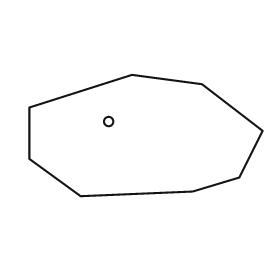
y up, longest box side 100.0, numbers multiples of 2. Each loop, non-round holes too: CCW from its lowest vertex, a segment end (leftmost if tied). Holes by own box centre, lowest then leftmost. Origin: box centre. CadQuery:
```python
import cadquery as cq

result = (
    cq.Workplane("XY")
    .moveTo(-28.0, -26.0)
    .lineTo(20.0, -24.0)
    .lineTo(40.0, -18.0)
    .lineTo(50.0, 2.0)
    .lineTo(24.0, 22.0)
    .lineTo(-6.0, 26.0)
    .lineTo(-50.0, 12.0)
    .lineTo(-50.0, -10.0)
    .close()
    .moveTo(-16.0, 6.0)
    .circle(2.0)
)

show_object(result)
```